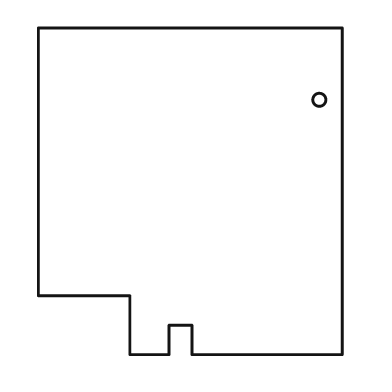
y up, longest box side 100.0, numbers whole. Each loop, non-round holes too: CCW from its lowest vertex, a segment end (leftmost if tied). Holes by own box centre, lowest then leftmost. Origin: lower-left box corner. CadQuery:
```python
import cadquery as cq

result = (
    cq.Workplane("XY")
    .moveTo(28.0, 0.0)
    .lineTo(40.0, 0.0)
    .lineTo(40.0, 9.0)
    .lineTo(47.0, 9.0)
    .lineTo(47.0, 0.0)
    .lineTo(93.0, 0.0)
    .lineTo(93.0, 100.0)
    .lineTo(0.0, 100.0)
    .lineTo(0.0, 18.0)
    .lineTo(28.0, 18.0)
    .close()
    .moveTo(86.0, 78.0)
    .circle(2.0)
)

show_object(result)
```